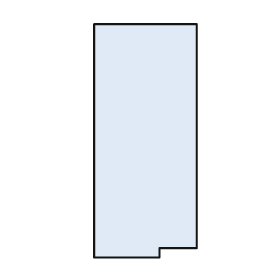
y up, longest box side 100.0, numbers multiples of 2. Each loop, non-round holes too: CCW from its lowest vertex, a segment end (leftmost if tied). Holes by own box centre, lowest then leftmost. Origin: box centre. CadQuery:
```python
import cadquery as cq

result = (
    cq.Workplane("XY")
    .moveTo(-22.0, -50.0)
    .lineTo(6.0, -50.0)
    .lineTo(6.0, -46.0)
    .lineTo(22.0, -46.0)
    .lineTo(22.0, 50.0)
    .lineTo(-22.0, 50.0)
    .close()
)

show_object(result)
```